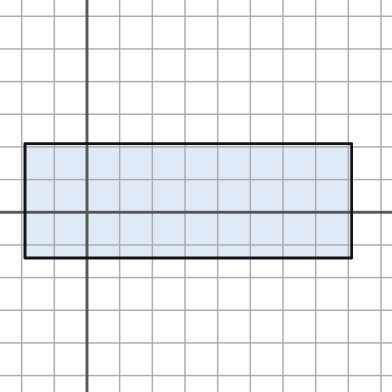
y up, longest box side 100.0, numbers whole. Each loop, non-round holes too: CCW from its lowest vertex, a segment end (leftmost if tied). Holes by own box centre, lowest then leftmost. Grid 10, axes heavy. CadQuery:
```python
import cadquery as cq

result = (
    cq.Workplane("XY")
    .moveTo(-19.0, -14.0)
    .lineTo(81.0, -14.0)
    .lineTo(81.0, 21.0)
    .lineTo(-19.0, 21.0)
    .close()
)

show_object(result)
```